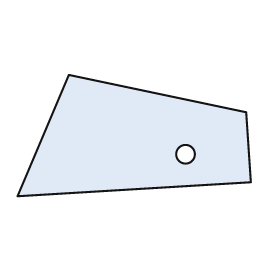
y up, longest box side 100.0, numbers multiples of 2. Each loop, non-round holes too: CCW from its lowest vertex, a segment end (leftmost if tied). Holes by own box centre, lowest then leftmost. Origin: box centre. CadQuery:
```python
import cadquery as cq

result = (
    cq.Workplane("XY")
    .moveTo(-50.0, -26.0)
    .lineTo(50.0, -20.0)
    .lineTo(48.0, 10.0)
    .lineTo(-28.0, 26.0)
    .close()
    .moveTo(22.0, -8.0)
    .circle(4.0)
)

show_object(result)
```